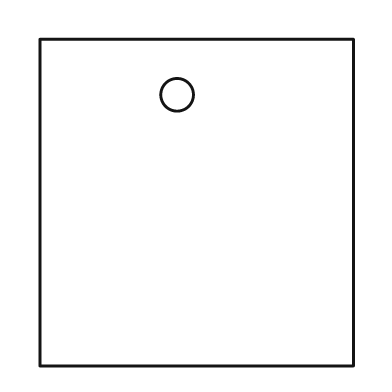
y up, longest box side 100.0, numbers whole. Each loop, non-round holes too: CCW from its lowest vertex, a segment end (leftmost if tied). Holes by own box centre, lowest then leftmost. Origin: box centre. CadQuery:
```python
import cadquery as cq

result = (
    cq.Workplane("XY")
    .moveTo(-48.0, -50.0)
    .lineTo(48.0, -50.0)
    .lineTo(48.0, 50.0)
    .lineTo(-48.0, 50.0)
    .close()
    .moveTo(-6.0, 33.0)
    .circle(5.0)
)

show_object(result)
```